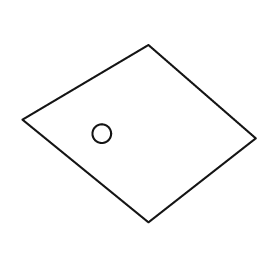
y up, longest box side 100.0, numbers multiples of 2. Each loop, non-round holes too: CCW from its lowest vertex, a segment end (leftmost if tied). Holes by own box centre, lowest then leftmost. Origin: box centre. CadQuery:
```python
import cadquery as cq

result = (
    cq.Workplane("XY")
    .moveTo(4.0, -38.0)
    .lineTo(50.0, -2.0)
    .lineTo(4.0, 38.0)
    .lineTo(-50.0, 6.0)
    .close()
    .moveTo(-16.0, 0.0)
    .circle(4.0)
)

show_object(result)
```